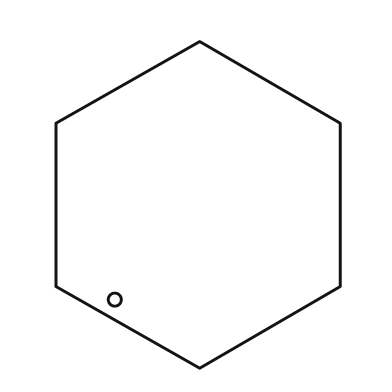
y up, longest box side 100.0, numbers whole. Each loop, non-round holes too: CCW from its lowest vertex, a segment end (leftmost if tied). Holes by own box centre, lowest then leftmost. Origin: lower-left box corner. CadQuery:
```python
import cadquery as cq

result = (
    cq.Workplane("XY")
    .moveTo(44.0, 0.0)
    .lineTo(87.0, 25.0)
    .lineTo(87.0, 75.0)
    .lineTo(44.0, 100.0)
    .lineTo(0.0, 75.0)
    .lineTo(0.0, 25.0)
    .close()
    .moveTo(18.0, 21.0)
    .circle(2.0)
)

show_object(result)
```